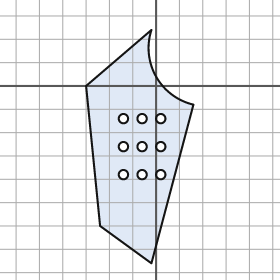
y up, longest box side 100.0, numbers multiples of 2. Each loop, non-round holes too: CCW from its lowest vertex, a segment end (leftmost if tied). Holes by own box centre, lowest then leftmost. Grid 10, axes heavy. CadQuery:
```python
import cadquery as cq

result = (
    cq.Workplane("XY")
    .moveTo(-2.0, -76.0)
    .lineTo(16.0, -8.0)
    .threePointArc((0.0, 4.0), (-2.0, 24.0))
    .lineTo(-30.0, 0.0)
    .lineTo(-24.0, -60.0)
    .close()
    .moveTo(-14.0, -38.0)
    .circle(2.0)
    .moveTo(-6.0, -38.0)
    .circle(2.0)
    .moveTo(2.0, -38.0)
    .circle(2.0)
    .moveTo(-14.0, -26.0)
    .circle(2.0)
    .moveTo(-6.0, -26.0)
    .circle(2.0)
    .moveTo(2.0, -26.0)
    .circle(2.0)
    .moveTo(-14.0, -14.0)
    .circle(2.0)
    .moveTo(-6.0, -14.0)
    .circle(2.0)
    .moveTo(2.0, -14.0)
    .circle(2.0)
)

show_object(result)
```